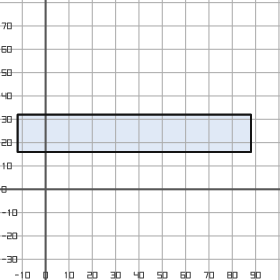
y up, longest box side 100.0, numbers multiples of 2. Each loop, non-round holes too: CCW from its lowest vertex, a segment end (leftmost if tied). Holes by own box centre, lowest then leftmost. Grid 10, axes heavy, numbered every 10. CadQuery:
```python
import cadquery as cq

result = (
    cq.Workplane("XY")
    .moveTo(-12.0, 16.0)
    .lineTo(88.0, 16.0)
    .lineTo(88.0, 32.0)
    .lineTo(-12.0, 32.0)
    .close()
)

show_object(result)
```